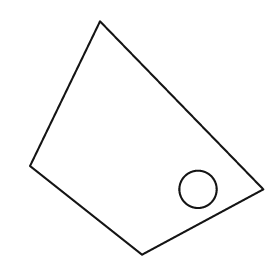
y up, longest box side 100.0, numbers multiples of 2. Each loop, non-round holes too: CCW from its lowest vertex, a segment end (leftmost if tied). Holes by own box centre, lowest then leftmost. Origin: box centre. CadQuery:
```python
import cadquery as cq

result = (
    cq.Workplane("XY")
    .moveTo(-2.0, -50.0)
    .lineTo(50.0, -22.0)
    .lineTo(-20.0, 50.0)
    .lineTo(-50.0, -12.0)
    .close()
    .moveTo(22.0, -22.0)
    .circle(8.0)
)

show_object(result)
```